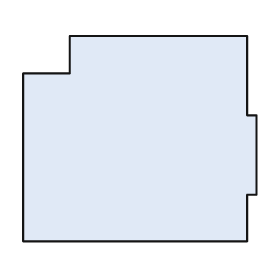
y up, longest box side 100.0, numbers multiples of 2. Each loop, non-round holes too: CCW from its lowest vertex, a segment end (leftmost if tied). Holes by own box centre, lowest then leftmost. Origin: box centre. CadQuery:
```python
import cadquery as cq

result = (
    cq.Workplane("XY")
    .moveTo(-50.0, -44.0)
    .lineTo(46.0, -44.0)
    .lineTo(46.0, -24.0)
    .lineTo(50.0, -24.0)
    .lineTo(50.0, 10.0)
    .lineTo(46.0, 10.0)
    .lineTo(46.0, 44.0)
    .lineTo(-30.0, 44.0)
    .lineTo(-30.0, 28.0)
    .lineTo(-50.0, 28.0)
    .close()
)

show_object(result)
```